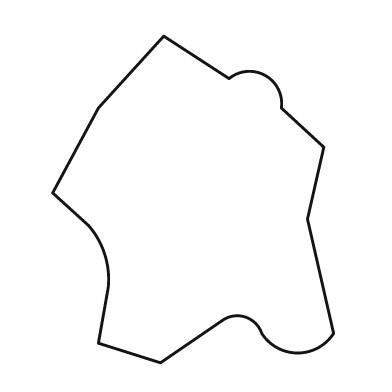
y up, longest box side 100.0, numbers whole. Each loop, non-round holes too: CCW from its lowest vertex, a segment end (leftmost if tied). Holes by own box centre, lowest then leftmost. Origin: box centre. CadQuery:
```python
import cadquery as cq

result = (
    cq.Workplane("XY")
    .moveTo(-10.0, -50.0)
    .lineTo(9.0, -37.0)
    .threePointArc((16.0, -36.0), (21.0, -41.0))
    .threePointArc((32.0, -47.0), (43.0, -41.0))
    .lineTo(35.0, -6.0)
    .lineTo(40.0, 16.0)
    .lineTo(27.0, 28.0)
    .threePointArc((22.0, 38.0), (11.0, 37.0))
    .lineTo(-9.0, 50.0)
    .lineTo(-29.0, 28.0)
    .lineTo(-43.0, 2.0)
    .lineTo(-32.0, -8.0)
    .threePointArc((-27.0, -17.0), (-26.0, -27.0))
    .lineTo(-29.0, -44.0)
    .close()
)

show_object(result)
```